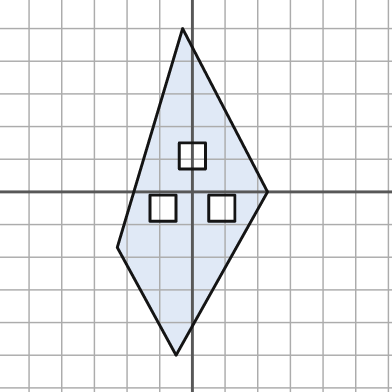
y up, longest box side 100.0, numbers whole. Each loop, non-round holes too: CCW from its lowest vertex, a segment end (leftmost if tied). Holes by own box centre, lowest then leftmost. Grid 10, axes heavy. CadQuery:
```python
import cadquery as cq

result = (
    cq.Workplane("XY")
    .moveTo(-5.0, -50.0)
    .lineTo(23.0, 0.0)
    .lineTo(-3.0, 50.0)
    .lineTo(-23.0, -17.0)
    .close()
    .moveTo(-13.0, -9.0)
    .lineTo(-5.0, -9.0)
    .lineTo(-5.0, -1.0)
    .lineTo(-13.0, -1.0)
    .close()
    .moveTo(5.0, -9.0)
    .lineTo(13.0, -9.0)
    .lineTo(13.0, -1.0)
    .lineTo(5.0, -1.0)
    .close()
    .moveTo(-4.0, 7.0)
    .lineTo(4.0, 7.0)
    .lineTo(4.0, 15.0)
    .lineTo(-4.0, 15.0)
    .close()
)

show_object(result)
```